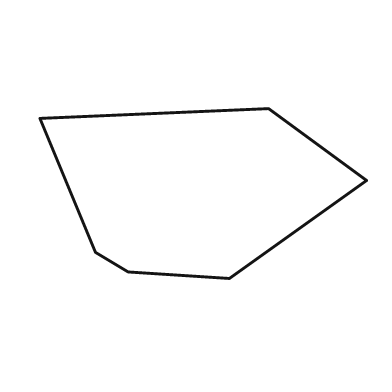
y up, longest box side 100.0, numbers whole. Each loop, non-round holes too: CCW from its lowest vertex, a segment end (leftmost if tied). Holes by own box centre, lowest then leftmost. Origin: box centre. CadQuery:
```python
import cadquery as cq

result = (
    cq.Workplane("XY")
    .moveTo(8.0, -26.0)
    .lineTo(50.0, 4.0)
    .lineTo(20.0, 26.0)
    .lineTo(-50.0, 23.0)
    .lineTo(-33.0, -18.0)
    .lineTo(-23.0, -24.0)
    .close()
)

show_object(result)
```